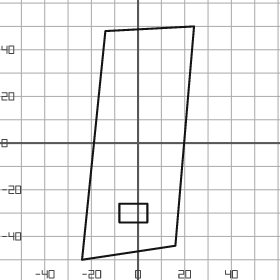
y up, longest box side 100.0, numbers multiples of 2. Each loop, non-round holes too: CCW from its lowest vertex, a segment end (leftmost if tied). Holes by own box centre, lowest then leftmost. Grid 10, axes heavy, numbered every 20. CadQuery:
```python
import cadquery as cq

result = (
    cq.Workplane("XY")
    .moveTo(-24.0, -50.0)
    .lineTo(16.0, -44.0)
    .lineTo(24.0, 50.0)
    .lineTo(-14.0, 48.0)
    .close()
    .moveTo(-8.0, -34.0)
    .lineTo(4.0, -34.0)
    .lineTo(4.0, -26.0)
    .lineTo(-8.0, -26.0)
    .close()
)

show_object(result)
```